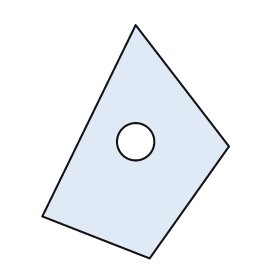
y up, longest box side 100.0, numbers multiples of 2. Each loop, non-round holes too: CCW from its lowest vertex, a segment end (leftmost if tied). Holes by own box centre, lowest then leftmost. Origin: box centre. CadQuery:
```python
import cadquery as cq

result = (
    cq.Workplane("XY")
    .moveTo(6.0, -50.0)
    .lineTo(40.0, -2.0)
    .lineTo(0.0, 50.0)
    .lineTo(-40.0, -32.0)
    .close()
    .moveTo(0.0, 0.0)
    .circle(8.0)
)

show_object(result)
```